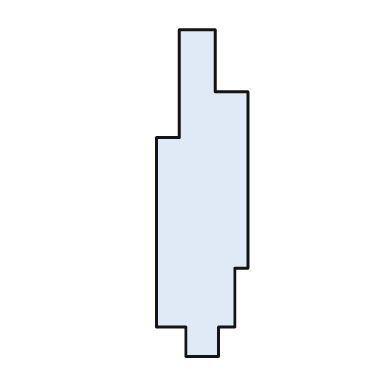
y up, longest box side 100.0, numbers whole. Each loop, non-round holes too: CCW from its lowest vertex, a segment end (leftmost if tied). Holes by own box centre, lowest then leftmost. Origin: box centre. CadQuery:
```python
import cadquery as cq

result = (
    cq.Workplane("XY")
    .moveTo(-5.0, -50.0)
    .lineTo(5.0, -50.0)
    .lineTo(5.0, -41.0)
    .lineTo(10.0, -41.0)
    .lineTo(10.0, -23.0)
    .lineTo(14.0, -23.0)
    .lineTo(14.0, 31.0)
    .lineTo(4.0, 31.0)
    .lineTo(4.0, 50.0)
    .lineTo(-7.0, 50.0)
    .lineTo(-7.0, 17.0)
    .lineTo(-14.0, 17.0)
    .lineTo(-14.0, -41.0)
    .lineTo(-5.0, -41.0)
    .close()
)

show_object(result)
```